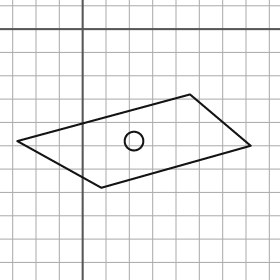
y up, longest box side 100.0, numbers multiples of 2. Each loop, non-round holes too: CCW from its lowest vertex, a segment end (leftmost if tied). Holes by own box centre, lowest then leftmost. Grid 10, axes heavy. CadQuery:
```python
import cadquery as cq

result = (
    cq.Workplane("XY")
    .moveTo(8.0, -68.0)
    .lineTo(72.0, -50.0)
    .lineTo(46.0, -28.0)
    .lineTo(-28.0, -48.0)
    .close()
    .moveTo(22.0, -48.0)
    .circle(4.0)
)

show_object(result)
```